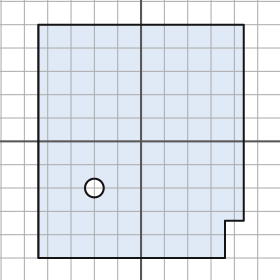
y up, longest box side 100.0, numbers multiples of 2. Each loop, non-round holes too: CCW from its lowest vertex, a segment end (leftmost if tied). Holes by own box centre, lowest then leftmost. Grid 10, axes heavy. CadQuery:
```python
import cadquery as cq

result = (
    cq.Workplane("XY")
    .moveTo(-44.0, -50.0)
    .lineTo(36.0, -50.0)
    .lineTo(36.0, -34.0)
    .lineTo(44.0, -34.0)
    .lineTo(44.0, 50.0)
    .lineTo(-44.0, 50.0)
    .close()
    .moveTo(-20.0, -20.0)
    .circle(4.0)
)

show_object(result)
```